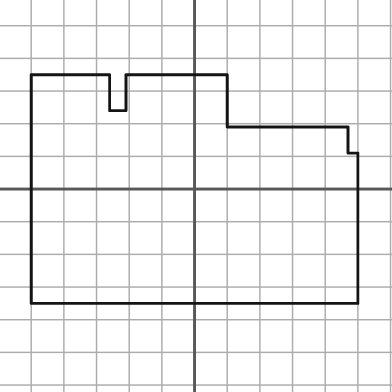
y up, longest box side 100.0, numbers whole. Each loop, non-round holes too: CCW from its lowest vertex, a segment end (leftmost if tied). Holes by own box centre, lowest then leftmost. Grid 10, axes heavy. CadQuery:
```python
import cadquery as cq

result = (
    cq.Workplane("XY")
    .moveTo(-50.0, -35.0)
    .lineTo(50.0, -35.0)
    .lineTo(50.0, 11.0)
    .lineTo(47.0, 11.0)
    .lineTo(47.0, 19.0)
    .lineTo(10.0, 19.0)
    .lineTo(10.0, 35.0)
    .lineTo(-21.0, 35.0)
    .lineTo(-21.0, 24.0)
    .lineTo(-26.0, 24.0)
    .lineTo(-26.0, 35.0)
    .lineTo(-50.0, 35.0)
    .close()
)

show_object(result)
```